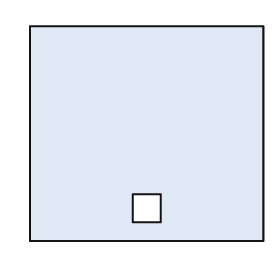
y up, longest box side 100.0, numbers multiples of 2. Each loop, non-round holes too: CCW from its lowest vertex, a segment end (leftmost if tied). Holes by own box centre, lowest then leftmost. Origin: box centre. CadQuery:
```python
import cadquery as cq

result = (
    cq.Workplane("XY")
    .moveTo(-50.0, -46.0)
    .lineTo(50.0, -46.0)
    .lineTo(50.0, 46.0)
    .lineTo(-50.0, 46.0)
    .close()
    .moveTo(-6.0, -38.0)
    .lineTo(6.0, -38.0)
    .lineTo(6.0, -26.0)
    .lineTo(-6.0, -26.0)
    .close()
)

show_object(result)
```